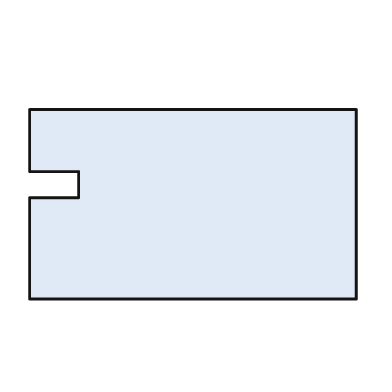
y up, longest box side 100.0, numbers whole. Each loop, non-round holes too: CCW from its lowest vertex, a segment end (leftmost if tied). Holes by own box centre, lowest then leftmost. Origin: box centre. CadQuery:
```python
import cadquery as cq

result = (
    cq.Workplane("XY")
    .moveTo(-50.0, -29.0)
    .lineTo(50.0, -29.0)
    .lineTo(50.0, 29.0)
    .lineTo(-50.0, 29.0)
    .lineTo(-50.0, 10.0)
    .lineTo(-35.0, 10.0)
    .lineTo(-35.0, 2.0)
    .lineTo(-50.0, 2.0)
    .close()
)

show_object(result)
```